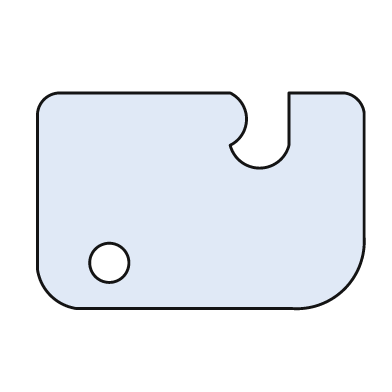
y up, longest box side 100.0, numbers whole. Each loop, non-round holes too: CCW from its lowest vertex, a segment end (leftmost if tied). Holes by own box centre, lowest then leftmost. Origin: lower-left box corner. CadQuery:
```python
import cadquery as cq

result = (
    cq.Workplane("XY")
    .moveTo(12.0, 0.0)
    .lineTo(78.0, 0.0)
    .threePointArc((94.0, 6.0), (100.0, 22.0))
    .lineTo(100.0, 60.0)
    .threePointArc((98.0, 64.0), (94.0, 66.0))
    .lineTo(77.0, 66.0)
    .lineTo(77.0, 50.0)
    .threePointArc((68.0, 43.0), (59.0, 50.0))
    .threePointArc((64.0, 58.0), (59.0, 66.0))
    .lineTo(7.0, 66.0)
    .threePointArc((2.0, 64.0), (0.0, 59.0))
    .lineTo(0.0, 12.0)
    .threePointArc((4.0, 4.0), (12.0, 0.0))
    .close()
    .moveTo(22.0, 14.0)
    .circle(6.0)
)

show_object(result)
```